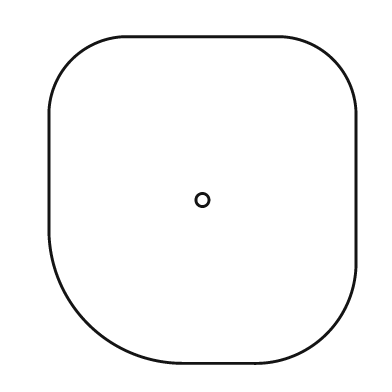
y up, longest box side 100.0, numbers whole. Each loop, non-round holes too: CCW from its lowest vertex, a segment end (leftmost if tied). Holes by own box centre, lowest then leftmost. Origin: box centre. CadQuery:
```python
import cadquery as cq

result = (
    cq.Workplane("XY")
    .moveTo(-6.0, -50.0)
    .lineTo(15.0, -50.0)
    .threePointArc((38.0, -41.0), (47.0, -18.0))
    .lineTo(47.0, 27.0)
    .threePointArc((40.0, 43.0), (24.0, 50.0))
    .lineTo(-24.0, 50.0)
    .threePointArc((-40.0, 43.0), (-47.0, 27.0))
    .lineTo(-47.0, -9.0)
    .threePointArc((-35.0, -38.0), (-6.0, -50.0))
    .close()
    .moveTo(0.0, 0.0)
    .circle(2.0)
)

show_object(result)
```